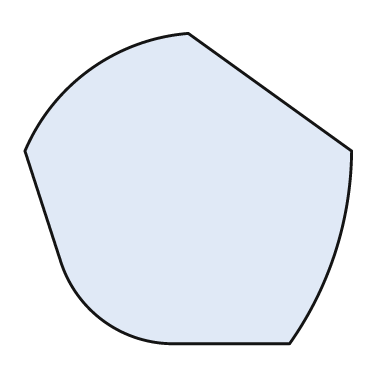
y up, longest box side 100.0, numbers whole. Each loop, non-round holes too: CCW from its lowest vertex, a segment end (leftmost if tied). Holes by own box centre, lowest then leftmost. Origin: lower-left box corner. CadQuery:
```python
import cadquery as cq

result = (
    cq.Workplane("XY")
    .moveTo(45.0, 0.0)
    .lineTo(81.0, 0.0)
    .threePointArc((95.0, 28.0), (100.0, 59.0))
    .lineTo(50.0, 95.0)
    .threePointArc((20.0, 84.0), (0.0, 59.0))
    .lineTo(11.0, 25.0)
    .threePointArc((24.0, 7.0), (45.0, 0.0))
    .close()
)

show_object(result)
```